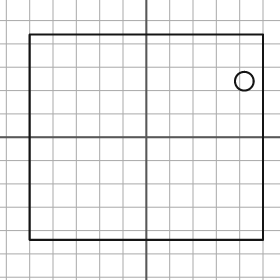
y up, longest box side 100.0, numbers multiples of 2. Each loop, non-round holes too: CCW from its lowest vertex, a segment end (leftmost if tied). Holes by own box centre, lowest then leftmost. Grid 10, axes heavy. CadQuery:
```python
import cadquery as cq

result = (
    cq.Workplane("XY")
    .moveTo(-50.0, -44.0)
    .lineTo(50.0, -44.0)
    .lineTo(50.0, 44.0)
    .lineTo(-50.0, 44.0)
    .close()
    .moveTo(42.0, 24.0)
    .circle(4.0)
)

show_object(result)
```